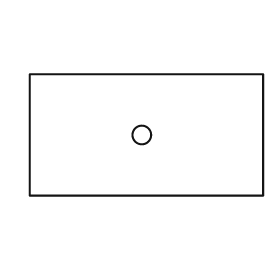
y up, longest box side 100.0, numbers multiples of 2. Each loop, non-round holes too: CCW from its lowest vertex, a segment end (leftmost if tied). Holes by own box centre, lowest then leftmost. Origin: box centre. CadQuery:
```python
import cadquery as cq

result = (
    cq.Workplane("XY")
    .moveTo(-50.0, -26.0)
    .lineTo(50.0, -26.0)
    .lineTo(50.0, 26.0)
    .lineTo(-50.0, 26.0)
    .close()
    .moveTo(-2.0, 0.0)
    .circle(4.0)
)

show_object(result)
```